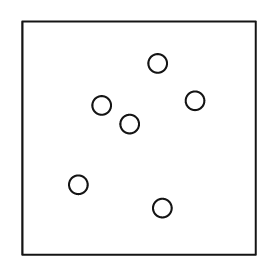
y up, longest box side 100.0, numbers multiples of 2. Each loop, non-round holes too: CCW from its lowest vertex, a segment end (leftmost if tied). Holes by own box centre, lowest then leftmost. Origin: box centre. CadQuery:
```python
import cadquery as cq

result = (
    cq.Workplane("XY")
    .moveTo(-50.0, -50.0)
    .lineTo(50.0, -50.0)
    .lineTo(50.0, 50.0)
    .lineTo(-50.0, 50.0)
    .close()
    .moveTo(10.0, -30.0)
    .circle(4.0)
    .moveTo(-26.0, -20.0)
    .circle(4.0)
    .moveTo(-4.0, 6.0)
    .circle(4.0)
    .moveTo(-16.0, 14.0)
    .circle(4.0)
    .moveTo(24.0, 16.0)
    .circle(4.0)
    .moveTo(8.0, 32.0)
    .circle(4.0)
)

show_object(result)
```